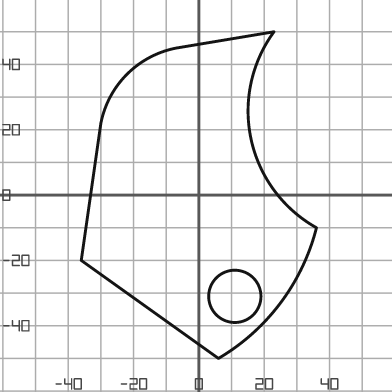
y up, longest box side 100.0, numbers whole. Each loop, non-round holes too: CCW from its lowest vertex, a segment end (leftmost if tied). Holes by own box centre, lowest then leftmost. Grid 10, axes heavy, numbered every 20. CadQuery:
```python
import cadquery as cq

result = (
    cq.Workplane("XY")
    .moveTo(6.0, -50.0)
    .threePointArc((25.0, -33.0), (36.0, -10.0))
    .threePointArc((16.0, 17.0), (23.0, 50.0))
    .lineTo(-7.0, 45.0)
    .threePointArc((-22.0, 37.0), (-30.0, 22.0))
    .lineTo(-36.0, -20.0)
    .close()
    .moveTo(11.0, -31.0)
    .circle(8.0)
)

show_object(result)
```